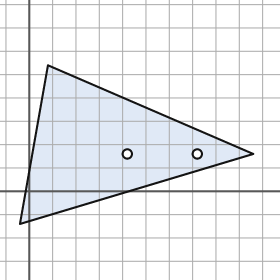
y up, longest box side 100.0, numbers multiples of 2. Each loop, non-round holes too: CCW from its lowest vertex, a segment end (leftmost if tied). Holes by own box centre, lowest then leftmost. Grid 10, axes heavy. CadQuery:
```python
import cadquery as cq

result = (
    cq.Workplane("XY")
    .moveTo(-4.0, -14.0)
    .lineTo(96.0, 16.0)
    .lineTo(8.0, 54.0)
    .close()
    .moveTo(42.0, 16.0)
    .circle(2.0)
    .moveTo(72.0, 16.0)
    .circle(2.0)
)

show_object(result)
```